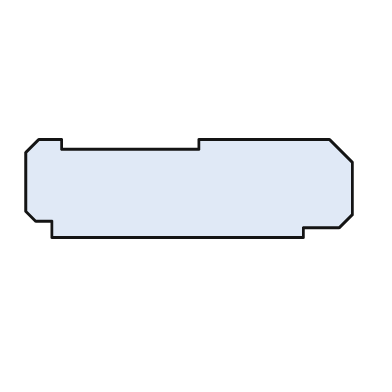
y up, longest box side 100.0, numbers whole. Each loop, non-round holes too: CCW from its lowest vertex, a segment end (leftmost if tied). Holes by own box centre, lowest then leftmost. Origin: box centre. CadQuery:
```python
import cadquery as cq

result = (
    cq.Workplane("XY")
    .moveTo(-42.0, -15.0)
    .lineTo(35.0, -15.0)
    .lineTo(35.0, -12.0)
    .lineTo(46.0, -12.0)
    .lineTo(50.0, -8.0)
    .lineTo(50.0, 8.0)
    .lineTo(43.0, 15.0)
    .lineTo(3.0, 15.0)
    .lineTo(3.0, 12.0)
    .lineTo(-39.0, 12.0)
    .lineTo(-39.0, 15.0)
    .lineTo(-46.0, 15.0)
    .lineTo(-50.0, 11.0)
    .lineTo(-50.0, -7.0)
    .lineTo(-47.0, -10.0)
    .lineTo(-42.0, -10.0)
    .close()
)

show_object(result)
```